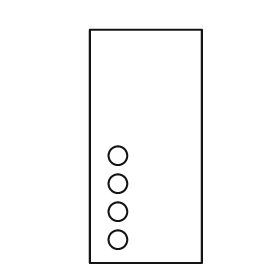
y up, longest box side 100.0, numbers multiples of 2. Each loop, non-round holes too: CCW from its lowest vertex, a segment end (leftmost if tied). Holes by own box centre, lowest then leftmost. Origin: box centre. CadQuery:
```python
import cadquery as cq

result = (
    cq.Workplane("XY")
    .moveTo(-24.0, -50.0)
    .lineTo(24.0, -50.0)
    .lineTo(24.0, 50.0)
    .lineTo(-24.0, 50.0)
    .close()
    .moveTo(-12.0, -40.0)
    .circle(4.0)
    .moveTo(-12.0, -28.0)
    .circle(4.0)
    .moveTo(-12.0, -16.0)
    .circle(4.0)
    .moveTo(-12.0, -4.0)
    .circle(4.0)
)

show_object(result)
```